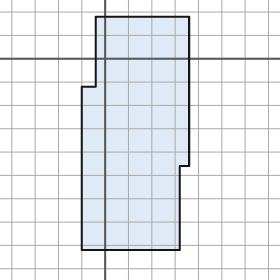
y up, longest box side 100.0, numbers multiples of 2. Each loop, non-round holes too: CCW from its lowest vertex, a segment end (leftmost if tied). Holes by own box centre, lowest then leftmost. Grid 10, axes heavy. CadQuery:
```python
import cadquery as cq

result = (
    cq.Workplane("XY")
    .moveTo(-10.0, -82.0)
    .lineTo(32.0, -82.0)
    .lineTo(32.0, -46.0)
    .lineTo(36.0, -46.0)
    .lineTo(36.0, 18.0)
    .lineTo(-4.0, 18.0)
    .lineTo(-4.0, -12.0)
    .lineTo(-10.0, -12.0)
    .close()
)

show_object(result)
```